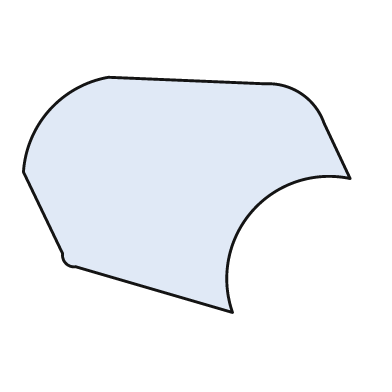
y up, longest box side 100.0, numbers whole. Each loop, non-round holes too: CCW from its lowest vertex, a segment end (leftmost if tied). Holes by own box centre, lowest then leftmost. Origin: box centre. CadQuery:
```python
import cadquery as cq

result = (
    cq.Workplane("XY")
    .moveTo(14.0, -36.0)
    .threePointArc((20.0, -5.0), (50.0, 5.0))
    .lineTo(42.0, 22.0)
    .threePointArc((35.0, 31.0), (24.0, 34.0))
    .lineTo(-24.0, 36.0)
    .threePointArc((-42.0, 26.0), (-50.0, 7.0))
    .lineTo(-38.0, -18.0)
    .threePointArc((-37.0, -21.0), (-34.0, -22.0))
    .close()
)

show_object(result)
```